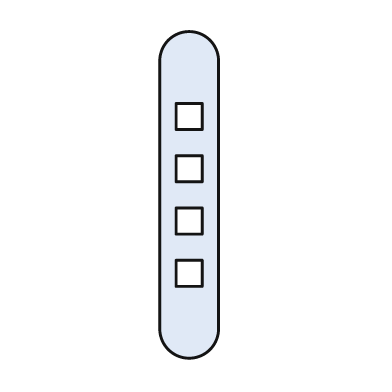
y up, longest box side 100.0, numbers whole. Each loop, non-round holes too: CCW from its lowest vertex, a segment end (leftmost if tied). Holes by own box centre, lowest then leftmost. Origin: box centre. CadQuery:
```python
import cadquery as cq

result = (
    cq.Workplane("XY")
    .moveTo(-9.0, -41.0)
    .threePointArc((0.0, -50.0), (9.0, -41.0))
    .lineTo(9.0, 41.0)
    .threePointArc((0.0, 50.0), (-9.0, 41.0))
    .close()
    .moveTo(-4.0, -28.0)
    .lineTo(4.0, -28.0)
    .lineTo(4.0, -20.0)
    .lineTo(-4.0, -20.0)
    .close()
    .moveTo(-4.0, -12.0)
    .lineTo(4.0, -12.0)
    .lineTo(4.0, -4.0)
    .lineTo(-4.0, -4.0)
    .close()
    .moveTo(-4.0, 4.0)
    .lineTo(4.0, 4.0)
    .lineTo(4.0, 12.0)
    .lineTo(-4.0, 12.0)
    .close()
    .moveTo(-4.0, 20.0)
    .lineTo(4.0, 20.0)
    .lineTo(4.0, 28.0)
    .lineTo(-4.0, 28.0)
    .close()
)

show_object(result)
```